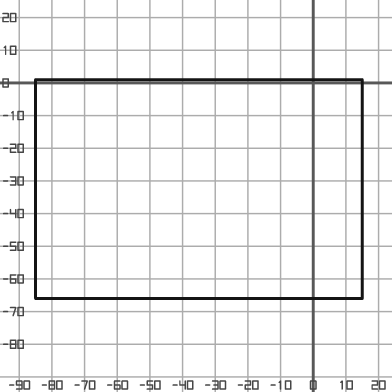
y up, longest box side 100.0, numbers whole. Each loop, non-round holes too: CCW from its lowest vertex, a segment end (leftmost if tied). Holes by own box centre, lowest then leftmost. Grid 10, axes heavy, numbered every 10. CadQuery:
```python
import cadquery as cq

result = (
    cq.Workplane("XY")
    .moveTo(-85.0, -66.0)
    .lineTo(15.0, -66.0)
    .lineTo(15.0, 1.0)
    .lineTo(-85.0, 1.0)
    .close()
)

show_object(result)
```